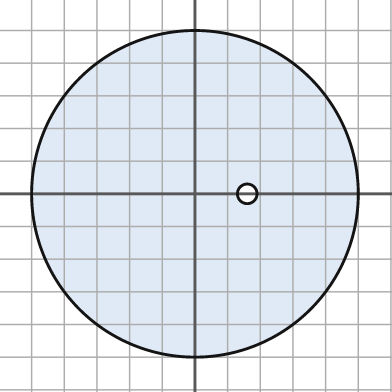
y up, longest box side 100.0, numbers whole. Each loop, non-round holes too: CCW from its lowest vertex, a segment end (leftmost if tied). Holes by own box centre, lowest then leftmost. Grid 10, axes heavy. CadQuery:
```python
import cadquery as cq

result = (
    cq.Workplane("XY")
    .moveTo(0.0, 0.0)
    .circle(50.0)
    .moveTo(16.0, 0.0)
    .circle(3.0)
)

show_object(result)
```